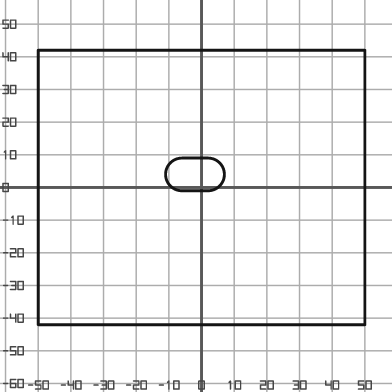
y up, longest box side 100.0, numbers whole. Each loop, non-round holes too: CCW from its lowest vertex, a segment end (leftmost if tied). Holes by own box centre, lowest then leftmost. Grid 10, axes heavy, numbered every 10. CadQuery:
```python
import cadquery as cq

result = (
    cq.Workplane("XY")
    .moveTo(-50.0, -42.0)
    .lineTo(50.0, -42.0)
    .lineTo(50.0, 42.0)
    .lineTo(-50.0, 42.0)
    .close()
    .moveTo(-6.0, -1.0)
    .lineTo(2.0, -1.0)
    .threePointArc((7.0, 4.0), (2.0, 9.0))
    .lineTo(-6.0, 9.0)
    .threePointArc((-11.0, 4.0), (-6.0, -1.0))
    .close()
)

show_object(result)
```